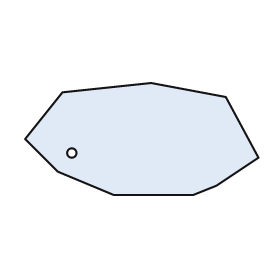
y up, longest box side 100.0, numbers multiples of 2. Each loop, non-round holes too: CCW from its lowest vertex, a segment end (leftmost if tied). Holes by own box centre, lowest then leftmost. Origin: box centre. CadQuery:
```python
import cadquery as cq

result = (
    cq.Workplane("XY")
    .moveTo(-12.0, -24.0)
    .lineTo(22.0, -24.0)
    .lineTo(32.0, -20.0)
    .lineTo(50.0, -8.0)
    .lineTo(36.0, 18.0)
    .lineTo(4.0, 24.0)
    .lineTo(-34.0, 20.0)
    .lineTo(-50.0, 0.0)
    .lineTo(-36.0, -14.0)
    .close()
    .moveTo(-30.0, -6.0)
    .circle(2.0)
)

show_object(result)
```